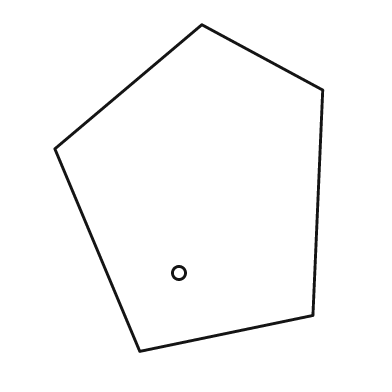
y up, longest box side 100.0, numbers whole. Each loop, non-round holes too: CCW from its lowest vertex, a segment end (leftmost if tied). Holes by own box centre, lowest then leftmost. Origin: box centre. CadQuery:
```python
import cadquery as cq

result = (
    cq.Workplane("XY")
    .moveTo(-15.0, -50.0)
    .lineTo(38.0, -39.0)
    .lineTo(41.0, 30.0)
    .lineTo(4.0, 50.0)
    .lineTo(-41.0, 12.0)
    .close()
    .moveTo(-3.0, -26.0)
    .circle(2.0)
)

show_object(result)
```